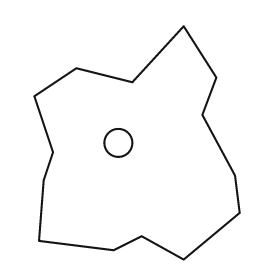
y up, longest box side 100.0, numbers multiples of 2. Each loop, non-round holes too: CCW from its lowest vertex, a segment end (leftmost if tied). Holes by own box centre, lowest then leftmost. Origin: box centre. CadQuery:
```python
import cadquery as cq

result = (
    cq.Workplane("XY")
    .moveTo(20.0, -50.0)
    .lineTo(44.0, -30.0)
    .lineTo(42.0, -14.0)
    .lineTo(28.0, 12.0)
    .lineTo(34.0, 28.0)
    .lineTo(20.0, 50.0)
    .lineTo(-2.0, 26.0)
    .lineTo(-26.0, 32.0)
    .lineTo(-44.0, 20.0)
    .lineTo(-36.0, -4.0)
    .lineTo(-40.0, -16.0)
    .lineTo(-42.0, -42.0)
    .lineTo(-10.0, -46.0)
    .lineTo(2.0, -40.0)
    .close()
    .moveTo(-8.0, 0.0)
    .circle(6.0)
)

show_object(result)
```